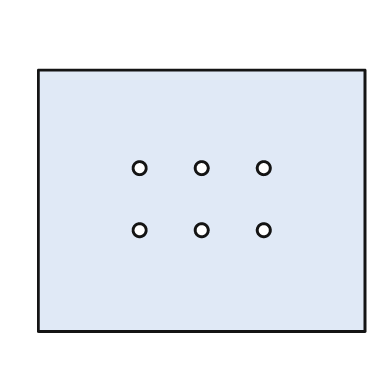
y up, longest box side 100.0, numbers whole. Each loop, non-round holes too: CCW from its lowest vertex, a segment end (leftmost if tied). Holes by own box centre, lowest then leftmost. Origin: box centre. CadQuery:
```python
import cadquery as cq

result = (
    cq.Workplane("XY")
    .moveTo(-50.0, -40.0)
    .lineTo(50.0, -40.0)
    .lineTo(50.0, 40.0)
    .lineTo(-50.0, 40.0)
    .close()
    .moveTo(-19.0, -9.0)
    .circle(2.0)
    .moveTo(0.0, -9.0)
    .circle(2.0)
    .moveTo(19.0, -9.0)
    .circle(2.0)
    .moveTo(-19.0, 10.0)
    .circle(2.0)
    .moveTo(0.0, 10.0)
    .circle(2.0)
    .moveTo(19.0, 10.0)
    .circle(2.0)
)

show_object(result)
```